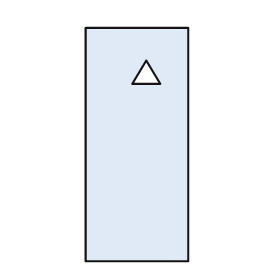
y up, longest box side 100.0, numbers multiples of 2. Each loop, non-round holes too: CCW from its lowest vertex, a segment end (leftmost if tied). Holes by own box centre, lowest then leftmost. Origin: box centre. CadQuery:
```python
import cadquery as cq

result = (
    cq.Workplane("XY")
    .moveTo(-22.0, -50.0)
    .lineTo(22.0, -50.0)
    .lineTo(22.0, 50.0)
    .lineTo(-22.0, 50.0)
    .close()
    .moveTo(-2.0, 26.0)
    .lineTo(10.0, 26.0)
    .lineTo(4.0, 36.0)
    .close()
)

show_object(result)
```